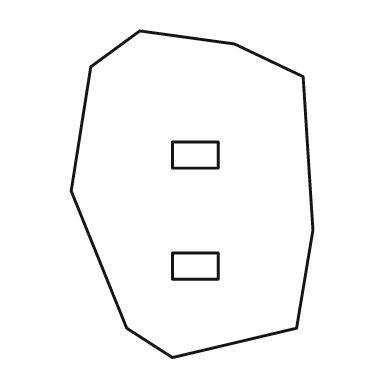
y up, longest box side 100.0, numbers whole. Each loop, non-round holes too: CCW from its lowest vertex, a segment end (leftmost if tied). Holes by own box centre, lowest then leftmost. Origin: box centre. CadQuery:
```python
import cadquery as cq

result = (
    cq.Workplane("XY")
    .moveTo(-6.0, -50.0)
    .lineTo(32.0, -41.0)
    .lineTo(37.0, -11.0)
    .lineTo(34.0, 36.0)
    .lineTo(13.0, 46.0)
    .lineTo(-16.0, 50.0)
    .lineTo(-31.0, 39.0)
    .lineTo(-37.0, 1.0)
    .lineTo(-20.0, -41.0)
    .close()
    .moveTo(-6.0, -26.0)
    .lineTo(8.0, -26.0)
    .lineTo(8.0, -18.0)
    .lineTo(-6.0, -18.0)
    .close()
    .moveTo(-6.0, 8.0)
    .lineTo(8.0, 8.0)
    .lineTo(8.0, 16.0)
    .lineTo(-6.0, 16.0)
    .close()
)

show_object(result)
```